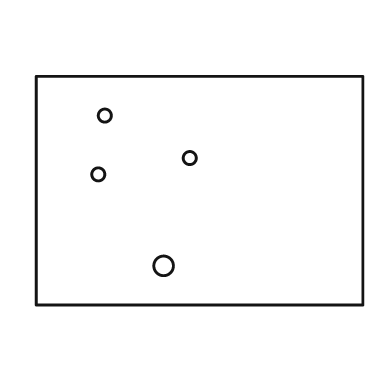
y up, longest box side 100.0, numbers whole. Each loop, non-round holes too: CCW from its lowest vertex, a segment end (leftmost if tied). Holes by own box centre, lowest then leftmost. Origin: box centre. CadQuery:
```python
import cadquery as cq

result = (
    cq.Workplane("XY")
    .moveTo(-50.0, -35.0)
    .lineTo(50.0, -35.0)
    .lineTo(50.0, 35.0)
    .lineTo(-50.0, 35.0)
    .close()
    .moveTo(-11.0, -23.0)
    .circle(3.0)
    .moveTo(-31.0, 5.0)
    .circle(2.0)
    .moveTo(-3.0, 10.0)
    .circle(2.0)
    .moveTo(-29.0, 23.0)
    .circle(2.0)
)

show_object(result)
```